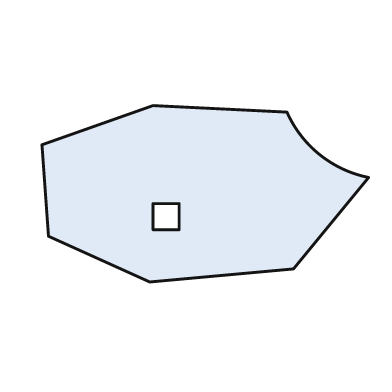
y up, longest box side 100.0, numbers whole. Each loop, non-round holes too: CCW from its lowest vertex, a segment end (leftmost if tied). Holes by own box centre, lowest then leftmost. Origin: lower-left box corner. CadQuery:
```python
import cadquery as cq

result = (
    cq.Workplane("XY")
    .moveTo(33.0, 0.0)
    .lineTo(77.0, 4.0)
    .lineTo(100.0, 32.0)
    .threePointArc((85.0, 39.0), (75.0, 52.0))
    .lineTo(34.0, 54.0)
    .lineTo(0.0, 42.0)
    .lineTo(2.0, 14.0)
    .close()
    .moveTo(34.0, 16.0)
    .lineTo(42.0, 16.0)
    .lineTo(42.0, 24.0)
    .lineTo(34.0, 24.0)
    .close()
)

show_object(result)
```